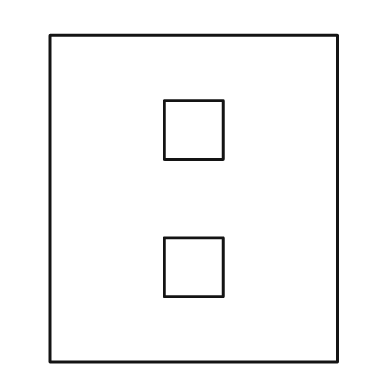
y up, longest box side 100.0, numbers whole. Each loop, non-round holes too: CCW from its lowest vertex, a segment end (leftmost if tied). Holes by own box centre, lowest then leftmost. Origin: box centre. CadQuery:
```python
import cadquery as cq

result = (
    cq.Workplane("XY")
    .moveTo(-44.0, -50.0)
    .lineTo(44.0, -50.0)
    .lineTo(44.0, 50.0)
    .lineTo(-44.0, 50.0)
    .close()
    .moveTo(-9.0, -30.0)
    .lineTo(9.0, -30.0)
    .lineTo(9.0, -12.0)
    .lineTo(-9.0, -12.0)
    .close()
    .moveTo(-9.0, 12.0)
    .lineTo(9.0, 12.0)
    .lineTo(9.0, 30.0)
    .lineTo(-9.0, 30.0)
    .close()
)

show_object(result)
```